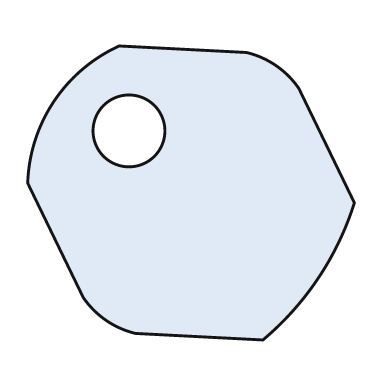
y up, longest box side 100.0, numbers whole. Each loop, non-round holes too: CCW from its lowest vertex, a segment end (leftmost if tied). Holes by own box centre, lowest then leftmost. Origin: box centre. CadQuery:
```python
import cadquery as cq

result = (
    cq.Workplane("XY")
    .moveTo(22.0, -45.0)
    .threePointArc((39.0, -26.0), (50.0, -3.0))
    .lineTo(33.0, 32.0)
    .threePointArc((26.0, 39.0), (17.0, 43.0))
    .lineTo(-22.0, 45.0)
    .threePointArc((-42.0, 28.0), (-50.0, 3.0))
    .lineTo(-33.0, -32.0)
    .threePointArc((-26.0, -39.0), (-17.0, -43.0))
    .close()
    .moveTo(-19.0, 19.0)
    .circle(11.0)
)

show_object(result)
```